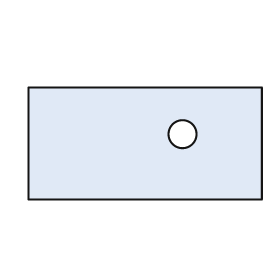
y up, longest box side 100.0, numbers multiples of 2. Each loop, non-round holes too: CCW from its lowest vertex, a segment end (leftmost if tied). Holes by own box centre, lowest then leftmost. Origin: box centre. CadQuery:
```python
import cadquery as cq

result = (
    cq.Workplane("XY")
    .moveTo(-50.0, -24.0)
    .lineTo(50.0, -24.0)
    .lineTo(50.0, 24.0)
    .lineTo(-50.0, 24.0)
    .close()
    .moveTo(16.0, 4.0)
    .circle(6.0)
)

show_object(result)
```